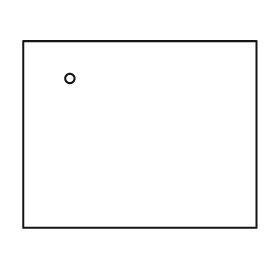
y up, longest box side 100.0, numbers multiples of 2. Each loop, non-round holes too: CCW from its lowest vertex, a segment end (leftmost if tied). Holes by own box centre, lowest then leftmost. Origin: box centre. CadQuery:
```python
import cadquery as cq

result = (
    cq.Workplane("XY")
    .moveTo(-50.0, -40.0)
    .lineTo(50.0, -40.0)
    .lineTo(50.0, 40.0)
    .lineTo(-50.0, 40.0)
    .close()
    .moveTo(-30.0, 24.0)
    .circle(2.0)
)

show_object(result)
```